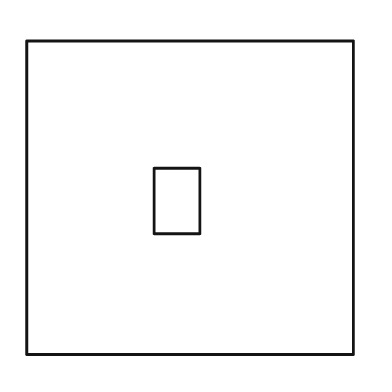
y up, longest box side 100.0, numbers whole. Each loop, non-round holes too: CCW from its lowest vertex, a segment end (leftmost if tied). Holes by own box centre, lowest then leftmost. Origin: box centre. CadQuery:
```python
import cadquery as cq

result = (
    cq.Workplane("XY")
    .moveTo(-50.0, -48.0)
    .lineTo(50.0, -48.0)
    .lineTo(50.0, 48.0)
    .lineTo(-50.0, 48.0)
    .close()
    .moveTo(-11.0, -11.0)
    .lineTo(3.0, -11.0)
    .lineTo(3.0, 9.0)
    .lineTo(-11.0, 9.0)
    .close()
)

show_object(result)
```